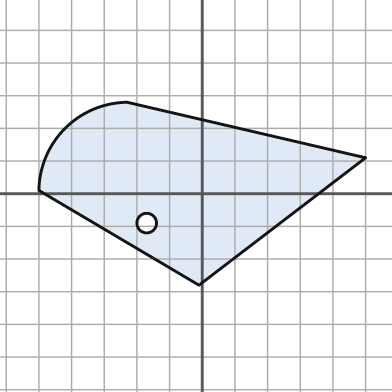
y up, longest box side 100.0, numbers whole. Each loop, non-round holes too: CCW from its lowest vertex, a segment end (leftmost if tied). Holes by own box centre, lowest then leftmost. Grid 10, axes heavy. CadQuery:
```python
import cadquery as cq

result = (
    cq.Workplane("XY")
    .moveTo(-1.0, -28.0)
    .lineTo(50.0, 11.0)
    .lineTo(-23.0, 28.0)
    .threePointArc((-42.0, 20.0), (-50.0, 1.0))
    .close()
    .moveTo(-17.0, -9.0)
    .circle(3.0)
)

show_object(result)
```